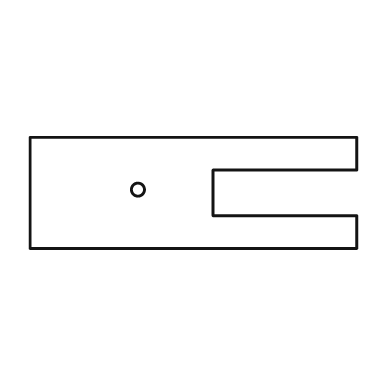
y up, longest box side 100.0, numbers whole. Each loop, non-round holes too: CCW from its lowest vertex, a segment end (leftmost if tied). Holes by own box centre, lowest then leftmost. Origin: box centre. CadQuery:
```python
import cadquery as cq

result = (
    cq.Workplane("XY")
    .moveTo(-50.0, -17.0)
    .lineTo(50.0, -17.0)
    .lineTo(50.0, -7.0)
    .lineTo(6.0, -7.0)
    .lineTo(6.0, 7.0)
    .lineTo(50.0, 7.0)
    .lineTo(50.0, 17.0)
    .lineTo(-50.0, 17.0)
    .close()
    .moveTo(-17.0, 1.0)
    .circle(2.0)
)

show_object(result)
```